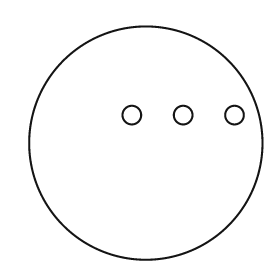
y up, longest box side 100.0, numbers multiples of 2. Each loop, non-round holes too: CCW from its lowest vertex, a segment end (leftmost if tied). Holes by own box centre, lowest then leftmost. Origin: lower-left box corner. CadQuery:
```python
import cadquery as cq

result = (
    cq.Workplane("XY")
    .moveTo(50.0, 50.0)
    .circle(50.0)
    .moveTo(44.0, 62.0)
    .circle(4.0)
    .moveTo(66.0, 62.0)
    .circle(4.0)
    .moveTo(88.0, 62.0)
    .circle(4.0)
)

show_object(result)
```